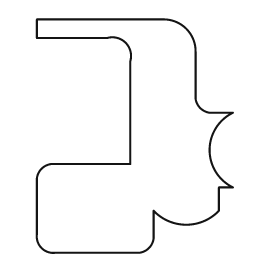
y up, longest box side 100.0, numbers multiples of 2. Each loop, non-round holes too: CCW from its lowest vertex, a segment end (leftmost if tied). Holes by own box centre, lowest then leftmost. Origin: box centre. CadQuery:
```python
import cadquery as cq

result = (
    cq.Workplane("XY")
    .moveTo(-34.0, -50.0)
    .lineTo(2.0, -50.0)
    .threePointArc((6.0, -48.0), (8.0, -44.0))
    .lineTo(8.0, -32.0)
    .threePointArc((22.0, -38.0), (36.0, -32.0))
    .lineTo(36.0, -22.0)
    .lineTo(42.0, -22.0)
    .threePointArc((32.0, -6.0), (42.0, 10.0))
    .lineTo(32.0, 10.0)
    .threePointArc((28.0, 12.0), (26.0, 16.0))
    .lineTo(26.0, 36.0)
    .threePointArc((22.0, 46.0), (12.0, 50.0))
    .lineTo(-42.0, 50.0)
    .lineTo(-42.0, 42.0)
    .lineTo(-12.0, 42.0)
    .threePointArc((-4.0, 40.0), (-2.0, 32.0))
    .lineTo(-2.0, -12.0)
    .lineTo(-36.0, -12.0)
    .threePointArc((-40.0, -14.0), (-42.0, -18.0))
    .lineTo(-42.0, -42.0)
    .threePointArc((-40.0, -48.0), (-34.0, -50.0))
    .close()
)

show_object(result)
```